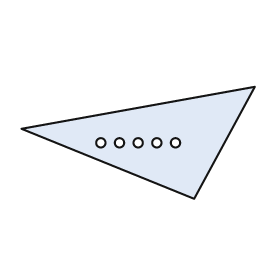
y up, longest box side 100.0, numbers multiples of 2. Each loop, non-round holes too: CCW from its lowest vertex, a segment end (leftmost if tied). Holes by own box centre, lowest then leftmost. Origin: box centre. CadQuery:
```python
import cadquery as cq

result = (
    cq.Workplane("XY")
    .moveTo(24.0, -24.0)
    .lineTo(50.0, 24.0)
    .lineTo(-50.0, 6.0)
    .close()
    .moveTo(-16.0, 0.0)
    .circle(2.0)
    .moveTo(-8.0, 0.0)
    .circle(2.0)
    .moveTo(0.0, 0.0)
    .circle(2.0)
    .moveTo(8.0, 0.0)
    .circle(2.0)
    .moveTo(16.0, 0.0)
    .circle(2.0)
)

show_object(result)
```